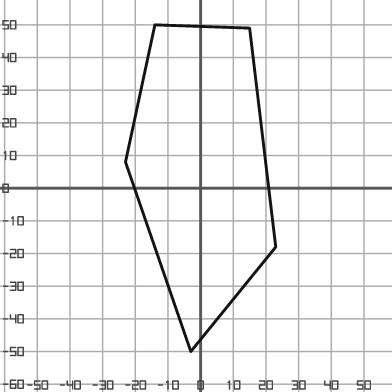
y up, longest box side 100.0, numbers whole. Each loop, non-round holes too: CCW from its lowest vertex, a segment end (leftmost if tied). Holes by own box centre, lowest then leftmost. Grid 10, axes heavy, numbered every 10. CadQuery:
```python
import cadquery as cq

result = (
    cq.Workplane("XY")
    .moveTo(-3.0, -50.0)
    .lineTo(23.0, -18.0)
    .lineTo(15.0, 49.0)
    .lineTo(-14.0, 50.0)
    .lineTo(-23.0, 8.0)
    .close()
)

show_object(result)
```